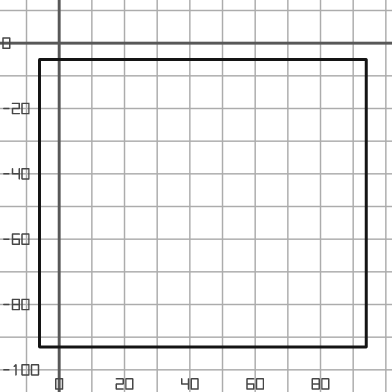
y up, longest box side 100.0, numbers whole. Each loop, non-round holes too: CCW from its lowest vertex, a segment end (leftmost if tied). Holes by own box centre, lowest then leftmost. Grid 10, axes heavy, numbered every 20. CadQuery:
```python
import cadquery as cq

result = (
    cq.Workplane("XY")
    .moveTo(-6.0, -93.0)
    .lineTo(94.0, -93.0)
    .lineTo(94.0, -5.0)
    .lineTo(-6.0, -5.0)
    .close()
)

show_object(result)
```